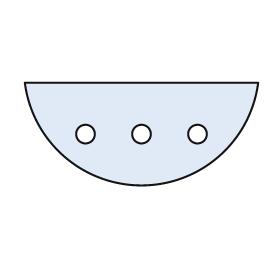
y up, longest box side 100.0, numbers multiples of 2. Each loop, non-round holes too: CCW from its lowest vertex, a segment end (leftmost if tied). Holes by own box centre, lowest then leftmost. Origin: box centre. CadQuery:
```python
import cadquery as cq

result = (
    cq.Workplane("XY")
    .moveTo(-50.0, 22.0)
    .threePointArc((0.0, -22.0), (50.0, 22.0))
    .close()
    .moveTo(-24.0, 0.0)
    .circle(4.0)
    .moveTo(0.0, 0.0)
    .circle(4.0)
    .moveTo(24.0, 0.0)
    .circle(4.0)
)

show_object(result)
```